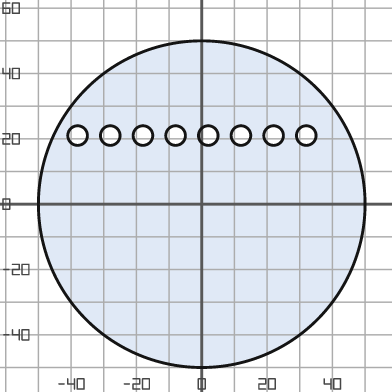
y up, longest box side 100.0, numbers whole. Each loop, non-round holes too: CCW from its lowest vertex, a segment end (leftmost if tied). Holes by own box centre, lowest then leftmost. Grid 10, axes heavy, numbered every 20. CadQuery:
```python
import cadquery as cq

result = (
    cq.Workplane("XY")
    .moveTo(0.0, 0.0)
    .circle(50.0)
    .moveTo(-38.0, 21.0)
    .circle(3.0)
    .moveTo(-28.0, 21.0)
    .circle(3.0)
    .moveTo(-18.0, 21.0)
    .circle(3.0)
    .moveTo(-8.0, 21.0)
    .circle(3.0)
    .moveTo(2.0, 21.0)
    .circle(3.0)
    .moveTo(12.0, 21.0)
    .circle(3.0)
    .moveTo(22.0, 21.0)
    .circle(3.0)
    .moveTo(32.0, 21.0)
    .circle(3.0)
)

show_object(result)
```